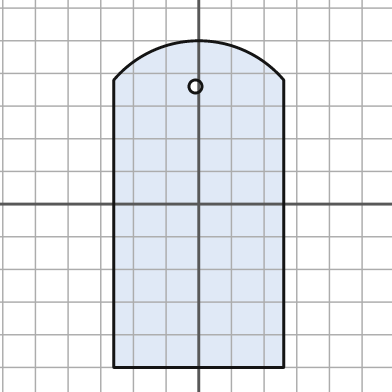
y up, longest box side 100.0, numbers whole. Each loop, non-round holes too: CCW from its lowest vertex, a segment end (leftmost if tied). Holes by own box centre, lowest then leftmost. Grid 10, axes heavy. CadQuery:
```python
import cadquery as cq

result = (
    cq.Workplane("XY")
    .moveTo(-26.0, -50.0)
    .lineTo(26.0, -50.0)
    .lineTo(26.0, 38.0)
    .threePointArc((0.0, 50.0), (-26.0, 38.0))
    .close()
    .moveTo(-1.0, 36.0)
    .circle(2.0)
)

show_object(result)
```